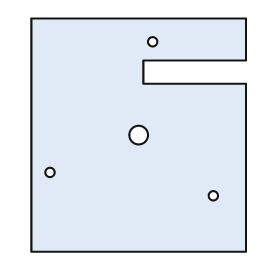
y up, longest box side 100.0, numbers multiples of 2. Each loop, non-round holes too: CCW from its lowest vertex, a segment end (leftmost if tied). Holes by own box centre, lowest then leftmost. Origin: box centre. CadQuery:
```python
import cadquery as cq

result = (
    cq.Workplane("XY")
    .moveTo(-46.0, -50.0)
    .lineTo(46.0, -50.0)
    .lineTo(46.0, 22.0)
    .lineTo(2.0, 22.0)
    .lineTo(2.0, 32.0)
    .lineTo(46.0, 32.0)
    .lineTo(46.0, 50.0)
    .lineTo(-46.0, 50.0)
    .close()
    .moveTo(32.0, -26.0)
    .circle(2.0)
    .moveTo(-38.0, -16.0)
    .circle(2.0)
    .moveTo(0.0, 0.0)
    .circle(4.0)
    .moveTo(6.0, 40.0)
    .circle(2.0)
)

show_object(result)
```